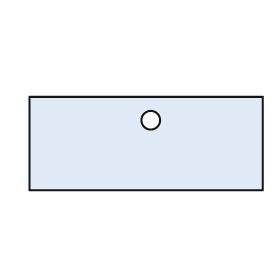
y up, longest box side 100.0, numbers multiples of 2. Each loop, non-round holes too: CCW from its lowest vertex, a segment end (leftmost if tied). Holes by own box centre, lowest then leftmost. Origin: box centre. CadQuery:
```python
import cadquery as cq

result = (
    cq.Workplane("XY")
    .moveTo(-50.0, -20.0)
    .lineTo(50.0, -20.0)
    .lineTo(50.0, 20.0)
    .lineTo(-50.0, 20.0)
    .close()
    .moveTo(2.0, 10.0)
    .circle(4.0)
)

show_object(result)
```